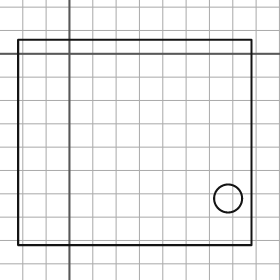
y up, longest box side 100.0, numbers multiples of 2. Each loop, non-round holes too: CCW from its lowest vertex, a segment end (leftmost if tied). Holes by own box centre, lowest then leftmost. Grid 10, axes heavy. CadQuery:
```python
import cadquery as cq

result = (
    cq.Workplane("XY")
    .moveTo(-22.0, -82.0)
    .lineTo(78.0, -82.0)
    .lineTo(78.0, 6.0)
    .lineTo(-22.0, 6.0)
    .close()
    .moveTo(68.0, -62.0)
    .circle(6.0)
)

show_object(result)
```